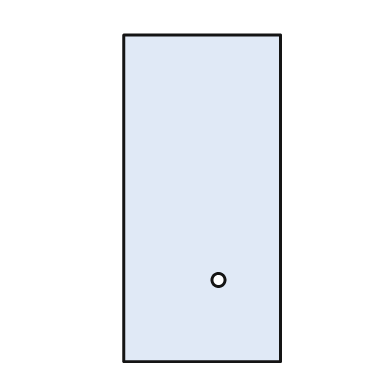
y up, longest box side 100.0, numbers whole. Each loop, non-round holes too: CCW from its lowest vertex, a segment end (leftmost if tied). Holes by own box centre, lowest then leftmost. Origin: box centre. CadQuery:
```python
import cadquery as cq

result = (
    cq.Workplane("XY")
    .moveTo(-24.0, -50.0)
    .lineTo(24.0, -50.0)
    .lineTo(24.0, 50.0)
    .lineTo(-24.0, 50.0)
    .close()
    .moveTo(5.0, -25.0)
    .circle(2.0)
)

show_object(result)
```